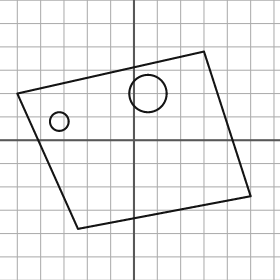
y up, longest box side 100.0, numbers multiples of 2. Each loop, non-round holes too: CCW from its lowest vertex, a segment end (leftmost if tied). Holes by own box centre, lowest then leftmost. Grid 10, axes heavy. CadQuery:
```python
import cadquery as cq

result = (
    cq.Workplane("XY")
    .moveTo(-24.0, -38.0)
    .lineTo(50.0, -24.0)
    .lineTo(30.0, 38.0)
    .lineTo(-50.0, 20.0)
    .close()
    .moveTo(-32.0, 8.0)
    .circle(4.0)
    .moveTo(6.0, 20.0)
    .circle(8.0)
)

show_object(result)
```